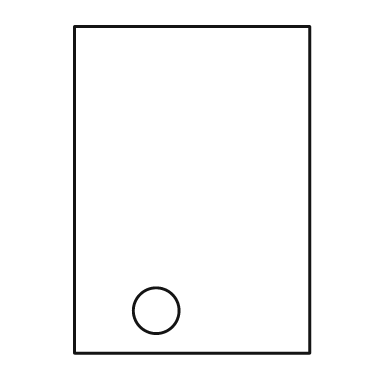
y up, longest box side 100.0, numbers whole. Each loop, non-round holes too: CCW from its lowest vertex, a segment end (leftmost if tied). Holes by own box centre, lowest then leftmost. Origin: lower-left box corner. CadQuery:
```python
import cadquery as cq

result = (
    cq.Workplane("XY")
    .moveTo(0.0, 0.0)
    .lineTo(72.0, 0.0)
    .lineTo(72.0, 100.0)
    .lineTo(0.0, 100.0)
    .close()
    .moveTo(25.0, 13.0)
    .circle(7.0)
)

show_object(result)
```